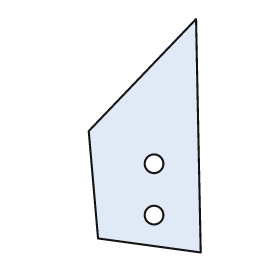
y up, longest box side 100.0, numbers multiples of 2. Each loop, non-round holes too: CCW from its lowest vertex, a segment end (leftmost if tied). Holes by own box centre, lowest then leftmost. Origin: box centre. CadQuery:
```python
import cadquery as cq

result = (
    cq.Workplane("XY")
    .moveTo(24.0, -50.0)
    .lineTo(22.0, 50.0)
    .lineTo(-24.0, 2.0)
    .lineTo(-20.0, -44.0)
    .close()
    .moveTo(4.0, -34.0)
    .circle(4.0)
    .moveTo(4.0, -12.0)
    .circle(4.0)
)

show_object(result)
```